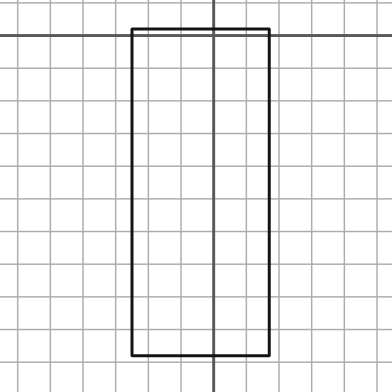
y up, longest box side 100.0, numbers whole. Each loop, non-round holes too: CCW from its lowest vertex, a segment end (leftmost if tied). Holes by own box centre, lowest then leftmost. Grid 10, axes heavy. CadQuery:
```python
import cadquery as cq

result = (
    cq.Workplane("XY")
    .moveTo(-25.0, -98.0)
    .lineTo(17.0, -98.0)
    .lineTo(17.0, 2.0)
    .lineTo(-25.0, 2.0)
    .close()
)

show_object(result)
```